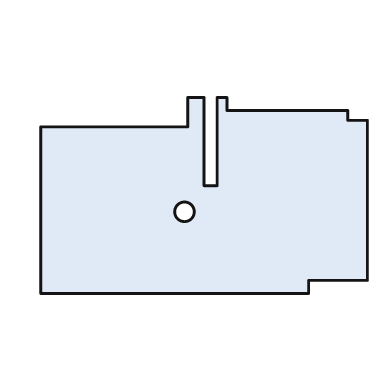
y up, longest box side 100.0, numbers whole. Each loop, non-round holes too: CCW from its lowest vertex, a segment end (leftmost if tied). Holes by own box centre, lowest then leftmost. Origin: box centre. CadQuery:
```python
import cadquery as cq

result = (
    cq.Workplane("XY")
    .moveTo(-50.0, -30.0)
    .lineTo(32.0, -30.0)
    .lineTo(32.0, -26.0)
    .lineTo(50.0, -26.0)
    .lineTo(50.0, 23.0)
    .lineTo(44.0, 23.0)
    .lineTo(44.0, 26.0)
    .lineTo(7.0, 26.0)
    .lineTo(7.0, 30.0)
    .lineTo(4.0, 30.0)
    .lineTo(4.0, 3.0)
    .lineTo(0.0, 3.0)
    .lineTo(0.0, 30.0)
    .lineTo(-5.0, 30.0)
    .lineTo(-5.0, 21.0)
    .lineTo(-50.0, 21.0)
    .close()
    .moveTo(-6.0, -5.0)
    .circle(3.0)
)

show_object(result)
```